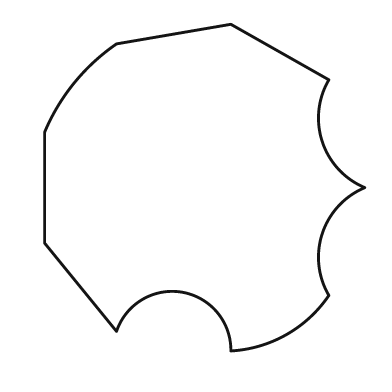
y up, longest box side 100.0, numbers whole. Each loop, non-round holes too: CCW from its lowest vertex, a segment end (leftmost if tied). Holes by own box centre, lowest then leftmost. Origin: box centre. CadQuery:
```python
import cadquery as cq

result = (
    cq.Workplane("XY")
    .moveTo(8.0, -50.0)
    .threePointArc((25.0, -45.0), (38.0, -33.0))
    .threePointArc((36.0, -14.0), (49.0, 0.0))
    .threePointArc((36.0, 14.0), (38.0, 33.0))
    .lineTo(8.0, 50.0)
    .lineTo(-27.0, 44.0)
    .threePointArc((-40.0, 32.0), (-49.0, 17.0))
    .lineTo(-49.0, -17.0)
    .lineTo(-27.0, -44.0)
    .threePointArc((-7.0, -32.0), (8.0, -50.0))
    .close()
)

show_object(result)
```